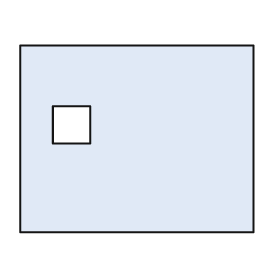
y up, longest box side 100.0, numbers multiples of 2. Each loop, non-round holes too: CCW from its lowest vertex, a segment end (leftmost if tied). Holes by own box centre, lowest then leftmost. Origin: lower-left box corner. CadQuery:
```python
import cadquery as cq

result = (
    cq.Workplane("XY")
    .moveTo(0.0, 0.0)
    .lineTo(100.0, 0.0)
    .lineTo(100.0, 80.0)
    .lineTo(0.0, 80.0)
    .close()
    .moveTo(14.0, 38.0)
    .lineTo(30.0, 38.0)
    .lineTo(30.0, 54.0)
    .lineTo(14.0, 54.0)
    .close()
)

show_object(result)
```